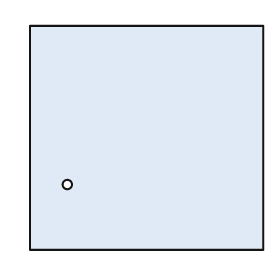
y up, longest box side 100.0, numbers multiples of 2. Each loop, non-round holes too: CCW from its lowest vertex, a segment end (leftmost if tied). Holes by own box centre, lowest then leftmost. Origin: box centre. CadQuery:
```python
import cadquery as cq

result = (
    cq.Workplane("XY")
    .moveTo(-50.0, -48.0)
    .lineTo(50.0, -48.0)
    .lineTo(50.0, 48.0)
    .lineTo(-50.0, 48.0)
    .close()
    .moveTo(-34.0, -20.0)
    .circle(2.0)
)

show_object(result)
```